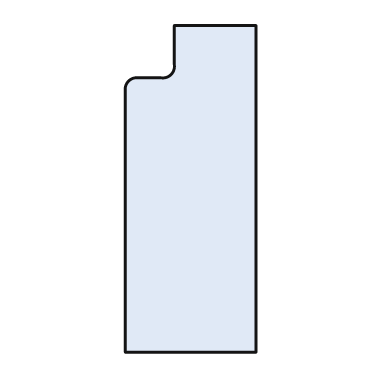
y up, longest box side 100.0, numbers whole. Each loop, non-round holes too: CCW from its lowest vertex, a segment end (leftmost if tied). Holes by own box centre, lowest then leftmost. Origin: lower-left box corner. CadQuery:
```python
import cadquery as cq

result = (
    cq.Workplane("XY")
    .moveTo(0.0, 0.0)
    .lineTo(40.0, 0.0)
    .lineTo(40.0, 100.0)
    .lineTo(15.0, 100.0)
    .lineTo(15.0, 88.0)
    .threePointArc((14.0, 85.0), (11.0, 84.0))
    .lineTo(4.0, 84.0)
    .threePointArc((1.0, 83.0), (0.0, 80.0))
    .close()
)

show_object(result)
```